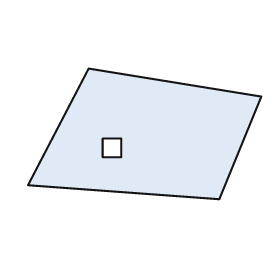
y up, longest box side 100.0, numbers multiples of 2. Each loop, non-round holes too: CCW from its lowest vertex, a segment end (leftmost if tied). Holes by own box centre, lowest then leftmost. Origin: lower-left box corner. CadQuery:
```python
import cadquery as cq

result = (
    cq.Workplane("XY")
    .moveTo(82.0, 0.0)
    .lineTo(100.0, 44.0)
    .lineTo(26.0, 56.0)
    .lineTo(0.0, 6.0)
    .close()
    .moveTo(32.0, 18.0)
    .lineTo(40.0, 18.0)
    .lineTo(40.0, 26.0)
    .lineTo(32.0, 26.0)
    .close()
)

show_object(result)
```